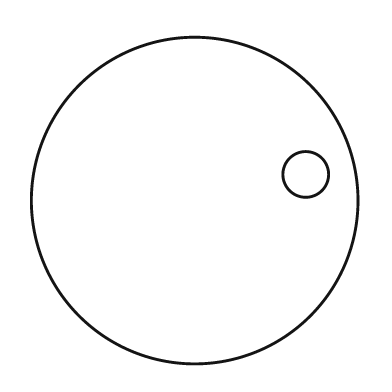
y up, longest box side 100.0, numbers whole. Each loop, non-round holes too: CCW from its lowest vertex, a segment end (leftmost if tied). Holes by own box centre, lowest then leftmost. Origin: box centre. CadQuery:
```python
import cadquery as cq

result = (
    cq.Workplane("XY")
    .moveTo(0.0, 0.0)
    .circle(50.0)
    .moveTo(34.0, 8.0)
    .circle(7.0)
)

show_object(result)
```